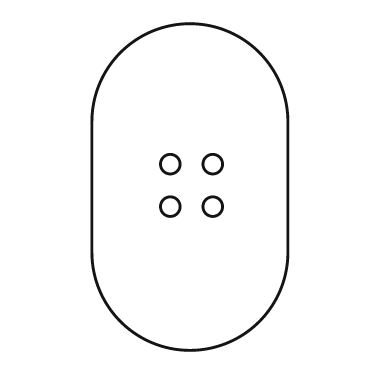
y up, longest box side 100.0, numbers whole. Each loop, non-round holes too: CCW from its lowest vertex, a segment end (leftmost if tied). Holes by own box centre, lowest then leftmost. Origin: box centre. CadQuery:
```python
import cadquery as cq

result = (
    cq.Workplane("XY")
    .moveTo(-30.0, -20.0)
    .threePointArc((0.0, -50.0), (30.0, -20.0))
    .lineTo(30.0, 20.0)
    .threePointArc((0.0, 50.0), (-30.0, 20.0))
    .close()
    .moveTo(-6.0, -6.0)
    .circle(3.0)
    .moveTo(7.0, -6.0)
    .circle(3.0)
    .moveTo(-6.0, 7.0)
    .circle(3.0)
    .moveTo(7.0, 7.0)
    .circle(3.0)
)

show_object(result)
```